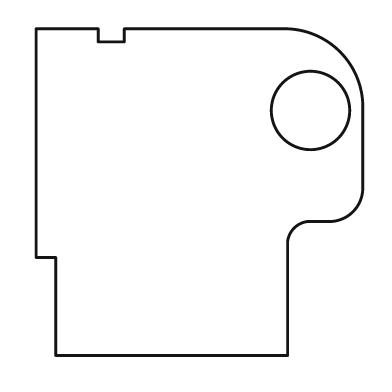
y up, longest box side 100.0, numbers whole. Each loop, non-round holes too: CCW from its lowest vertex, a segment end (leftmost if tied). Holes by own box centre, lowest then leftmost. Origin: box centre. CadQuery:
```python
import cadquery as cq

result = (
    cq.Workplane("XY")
    .moveTo(-44.0, -50.0)
    .lineTo(27.0, -50.0)
    .lineTo(27.0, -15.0)
    .threePointArc((29.0, -11.0), (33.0, -9.0))
    .lineTo(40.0, -9.0)
    .threePointArc((47.0, -6.0), (50.0, 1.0))
    .lineTo(50.0, 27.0)
    .threePointArc((43.0, 43.0), (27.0, 50.0))
    .lineTo(-23.0, 50.0)
    .lineTo(-23.0, 46.0)
    .lineTo(-31.0, 46.0)
    .lineTo(-31.0, 50.0)
    .lineTo(-50.0, 50.0)
    .lineTo(-50.0, -20.0)
    .lineTo(-44.0, -20.0)
    .close()
    .moveTo(34.0, 25.0)
    .circle(12.0)
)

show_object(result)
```